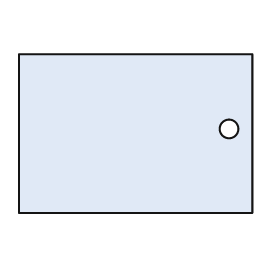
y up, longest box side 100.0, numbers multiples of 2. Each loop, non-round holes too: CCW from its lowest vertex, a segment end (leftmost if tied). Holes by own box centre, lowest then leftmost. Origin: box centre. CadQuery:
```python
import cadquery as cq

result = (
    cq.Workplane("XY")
    .moveTo(-50.0, -34.0)
    .lineTo(50.0, -34.0)
    .lineTo(50.0, 34.0)
    .lineTo(-50.0, 34.0)
    .close()
    .moveTo(40.0, 2.0)
    .circle(4.0)
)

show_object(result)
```